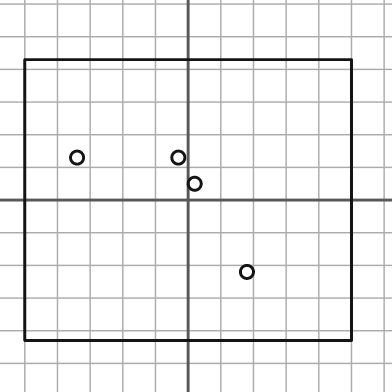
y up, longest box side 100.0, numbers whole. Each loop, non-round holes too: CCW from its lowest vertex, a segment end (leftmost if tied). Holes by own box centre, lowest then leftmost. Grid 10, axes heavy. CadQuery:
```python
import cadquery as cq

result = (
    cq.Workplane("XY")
    .moveTo(-50.0, -43.0)
    .lineTo(50.0, -43.0)
    .lineTo(50.0, 43.0)
    .lineTo(-50.0, 43.0)
    .close()
    .moveTo(18.0, -22.0)
    .circle(2.0)
    .moveTo(2.0, 5.0)
    .circle(2.0)
    .moveTo(-34.0, 13.0)
    .circle(2.0)
    .moveTo(-3.0, 13.0)
    .circle(2.0)
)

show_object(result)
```